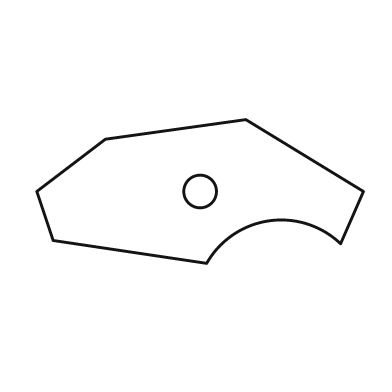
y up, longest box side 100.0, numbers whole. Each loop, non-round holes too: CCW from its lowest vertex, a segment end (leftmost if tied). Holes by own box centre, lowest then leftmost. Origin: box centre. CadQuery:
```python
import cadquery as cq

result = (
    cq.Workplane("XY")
    .moveTo(2.0, -22.0)
    .threePointArc((21.0, -9.0), (43.0, -16.0))
    .lineTo(50.0, 0.0)
    .lineTo(14.0, 22.0)
    .lineTo(-29.0, 16.0)
    .lineTo(-50.0, 0.0)
    .lineTo(-45.0, -15.0)
    .close()
    .moveTo(0.0, 0.0)
    .circle(5.0)
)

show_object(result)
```